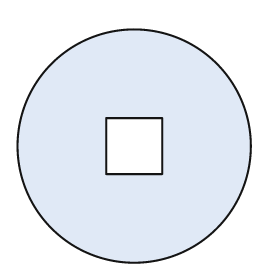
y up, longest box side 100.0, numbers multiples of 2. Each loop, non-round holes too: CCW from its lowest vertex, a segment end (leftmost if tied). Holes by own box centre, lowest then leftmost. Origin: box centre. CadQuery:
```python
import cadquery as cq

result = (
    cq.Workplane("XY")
    .moveTo(0.0, 0.0)
    .circle(50.0)
    .moveTo(-12.0, -12.0)
    .lineTo(12.0, -12.0)
    .lineTo(12.0, 12.0)
    .lineTo(-12.0, 12.0)
    .close()
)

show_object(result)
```